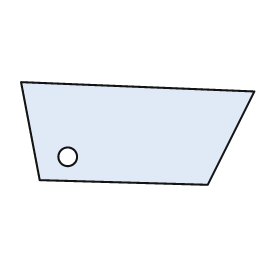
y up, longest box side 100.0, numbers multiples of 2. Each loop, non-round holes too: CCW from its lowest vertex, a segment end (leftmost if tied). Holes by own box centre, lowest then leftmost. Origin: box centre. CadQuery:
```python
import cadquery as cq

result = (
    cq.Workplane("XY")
    .moveTo(30.0, -22.0)
    .lineTo(50.0, 18.0)
    .lineTo(-50.0, 22.0)
    .lineTo(-42.0, -20.0)
    .close()
    .moveTo(-30.0, -10.0)
    .circle(4.0)
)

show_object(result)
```